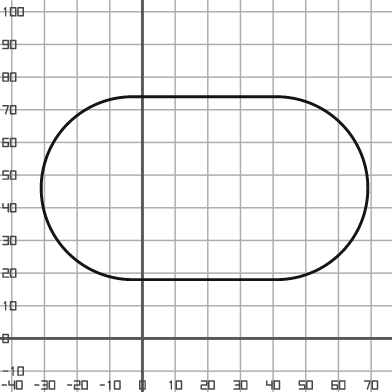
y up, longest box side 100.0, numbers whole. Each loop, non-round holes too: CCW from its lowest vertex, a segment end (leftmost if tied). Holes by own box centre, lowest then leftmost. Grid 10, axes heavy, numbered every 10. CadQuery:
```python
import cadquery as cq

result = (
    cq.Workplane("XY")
    .moveTo(-3.0, 18.0)
    .lineTo(41.0, 18.0)
    .threePointArc((69.0, 46.0), (41.0, 74.0))
    .lineTo(-3.0, 74.0)
    .threePointArc((-31.0, 46.0), (-3.0, 18.0))
    .close()
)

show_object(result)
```